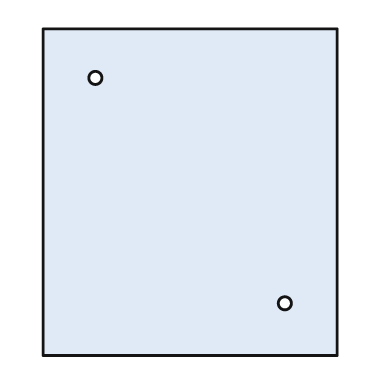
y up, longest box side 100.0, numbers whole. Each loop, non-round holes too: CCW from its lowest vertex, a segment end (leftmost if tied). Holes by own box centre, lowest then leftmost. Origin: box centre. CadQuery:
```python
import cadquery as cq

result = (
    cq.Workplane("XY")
    .moveTo(-45.0, -50.0)
    .lineTo(45.0, -50.0)
    .lineTo(45.0, 50.0)
    .lineTo(-45.0, 50.0)
    .close()
    .moveTo(29.0, -34.0)
    .circle(2.0)
    .moveTo(-29.0, 35.0)
    .circle(2.0)
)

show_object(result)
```